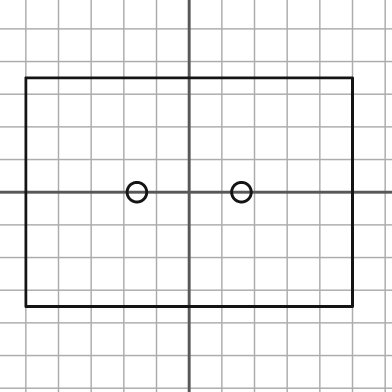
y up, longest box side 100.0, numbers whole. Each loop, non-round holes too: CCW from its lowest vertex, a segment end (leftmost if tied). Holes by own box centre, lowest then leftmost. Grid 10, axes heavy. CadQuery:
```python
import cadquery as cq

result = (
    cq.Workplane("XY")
    .moveTo(-50.0, -35.0)
    .lineTo(50.0, -35.0)
    .lineTo(50.0, 35.0)
    .lineTo(-50.0, 35.0)
    .close()
    .moveTo(-16.0, 0.0)
    .circle(3.0)
    .moveTo(16.0, 0.0)
    .circle(3.0)
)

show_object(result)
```